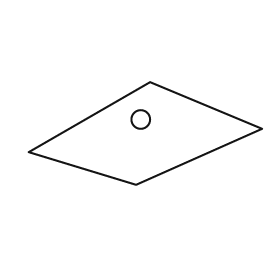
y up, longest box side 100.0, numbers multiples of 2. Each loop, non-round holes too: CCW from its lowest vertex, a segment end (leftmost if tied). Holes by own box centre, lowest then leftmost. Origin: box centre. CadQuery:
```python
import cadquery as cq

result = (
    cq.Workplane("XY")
    .moveTo(-4.0, -22.0)
    .lineTo(50.0, 2.0)
    .lineTo(2.0, 22.0)
    .lineTo(-50.0, -8.0)
    .close()
    .moveTo(-2.0, 6.0)
    .circle(4.0)
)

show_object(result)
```